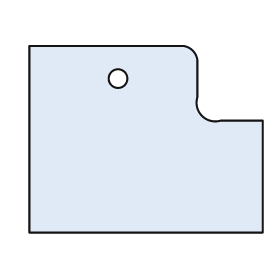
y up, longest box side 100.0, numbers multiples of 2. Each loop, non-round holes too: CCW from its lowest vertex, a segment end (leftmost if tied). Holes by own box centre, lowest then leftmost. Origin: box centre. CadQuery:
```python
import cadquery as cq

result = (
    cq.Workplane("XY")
    .moveTo(-50.0, -40.0)
    .lineTo(50.0, -40.0)
    .lineTo(50.0, 8.0)
    .lineTo(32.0, 8.0)
    .threePointArc((24.0, 10.0), (22.0, 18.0))
    .lineTo(22.0, 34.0)
    .threePointArc((20.0, 38.0), (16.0, 40.0))
    .lineTo(-50.0, 40.0)
    .close()
    .moveTo(-12.0, 26.0)
    .circle(4.0)
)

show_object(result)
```